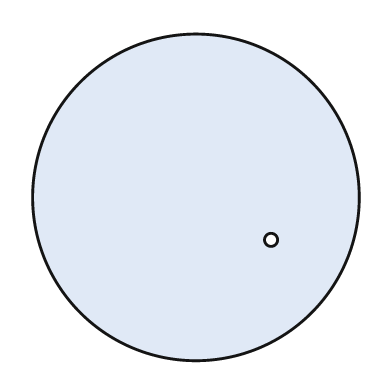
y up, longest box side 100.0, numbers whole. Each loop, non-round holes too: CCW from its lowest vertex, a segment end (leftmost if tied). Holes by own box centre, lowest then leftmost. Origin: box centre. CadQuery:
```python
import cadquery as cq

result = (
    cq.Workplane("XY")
    .moveTo(0.0, 0.0)
    .circle(50.0)
    .moveTo(23.0, -13.0)
    .circle(2.0)
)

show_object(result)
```